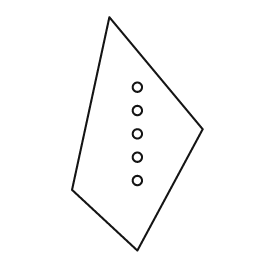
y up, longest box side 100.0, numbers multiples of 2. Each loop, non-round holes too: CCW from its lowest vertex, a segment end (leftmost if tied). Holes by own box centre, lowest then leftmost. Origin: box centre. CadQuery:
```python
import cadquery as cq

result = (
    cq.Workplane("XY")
    .moveTo(0.0, -50.0)
    .lineTo(28.0, 2.0)
    .lineTo(-12.0, 50.0)
    .lineTo(-28.0, -24.0)
    .close()
    .moveTo(0.0, -20.0)
    .circle(2.0)
    .moveTo(0.0, -10.0)
    .circle(2.0)
    .moveTo(0.0, 0.0)
    .circle(2.0)
    .moveTo(0.0, 10.0)
    .circle(2.0)
    .moveTo(0.0, 20.0)
    .circle(2.0)
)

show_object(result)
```